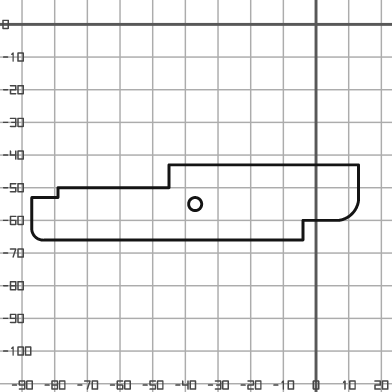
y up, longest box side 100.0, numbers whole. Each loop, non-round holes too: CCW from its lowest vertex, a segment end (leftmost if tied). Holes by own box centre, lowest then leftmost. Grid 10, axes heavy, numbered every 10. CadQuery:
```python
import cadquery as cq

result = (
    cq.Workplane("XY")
    .moveTo(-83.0, -66.0)
    .lineTo(-4.0, -66.0)
    .lineTo(-4.0, -60.0)
    .lineTo(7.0, -60.0)
    .threePointArc((11.0, -58.0), (13.0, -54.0))
    .lineTo(13.0, -43.0)
    .lineTo(-45.0, -43.0)
    .lineTo(-45.0, -50.0)
    .lineTo(-79.0, -50.0)
    .lineTo(-79.0, -53.0)
    .lineTo(-87.0, -53.0)
    .lineTo(-87.0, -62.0)
    .threePointArc((-86.0, -65.0), (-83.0, -66.0))
    .close()
    .moveTo(-37.0, -55.0)
    .circle(2.0)
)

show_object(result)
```